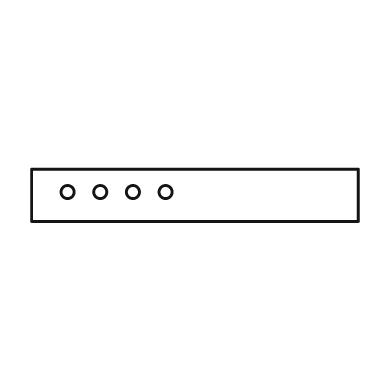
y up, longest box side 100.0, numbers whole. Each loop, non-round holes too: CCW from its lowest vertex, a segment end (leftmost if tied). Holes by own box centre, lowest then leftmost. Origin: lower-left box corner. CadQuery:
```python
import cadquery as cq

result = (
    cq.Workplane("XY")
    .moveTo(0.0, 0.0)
    .lineTo(100.0, 0.0)
    .lineTo(100.0, 16.0)
    .lineTo(0.0, 16.0)
    .close()
    .moveTo(11.0, 9.0)
    .circle(2.0)
    .moveTo(21.0, 9.0)
    .circle(2.0)
    .moveTo(31.0, 9.0)
    .circle(2.0)
    .moveTo(41.0, 9.0)
    .circle(2.0)
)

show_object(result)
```